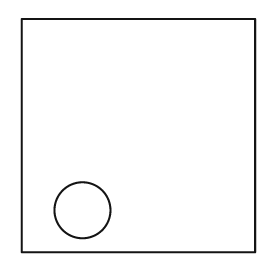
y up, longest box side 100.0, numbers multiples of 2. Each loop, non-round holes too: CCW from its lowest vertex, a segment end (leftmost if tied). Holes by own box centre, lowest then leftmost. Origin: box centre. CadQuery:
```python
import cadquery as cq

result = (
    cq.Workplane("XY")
    .moveTo(-50.0, -50.0)
    .lineTo(50.0, -50.0)
    .lineTo(50.0, 50.0)
    .lineTo(-50.0, 50.0)
    .close()
    .moveTo(-24.0, -32.0)
    .circle(12.0)
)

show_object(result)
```